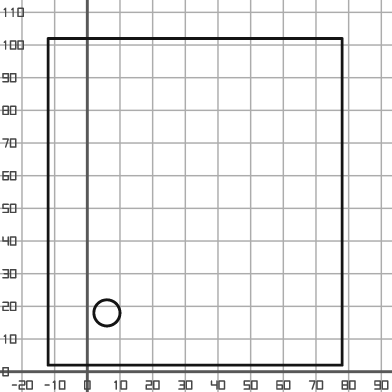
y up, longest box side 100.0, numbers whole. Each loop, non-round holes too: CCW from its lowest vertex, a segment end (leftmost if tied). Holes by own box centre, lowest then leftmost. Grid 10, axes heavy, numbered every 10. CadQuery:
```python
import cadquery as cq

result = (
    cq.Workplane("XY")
    .moveTo(-12.0, 2.0)
    .lineTo(78.0, 2.0)
    .lineTo(78.0, 102.0)
    .lineTo(-12.0, 102.0)
    .close()
    .moveTo(6.0, 18.0)
    .circle(4.0)
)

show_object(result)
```